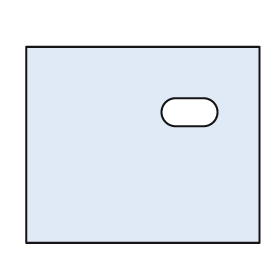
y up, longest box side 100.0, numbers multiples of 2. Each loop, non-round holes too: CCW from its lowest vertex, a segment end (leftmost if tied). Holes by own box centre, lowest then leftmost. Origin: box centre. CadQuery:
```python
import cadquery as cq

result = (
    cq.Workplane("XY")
    .moveTo(-50.0, -42.0)
    .lineTo(50.0, -42.0)
    .lineTo(50.0, 42.0)
    .lineTo(-50.0, 42.0)
    .close()
    .moveTo(14.0, 8.0)
    .lineTo(26.0, 8.0)
    .threePointArc((32.0, 14.0), (26.0, 20.0))
    .lineTo(14.0, 20.0)
    .threePointArc((8.0, 14.0), (14.0, 8.0))
    .close()
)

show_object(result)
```